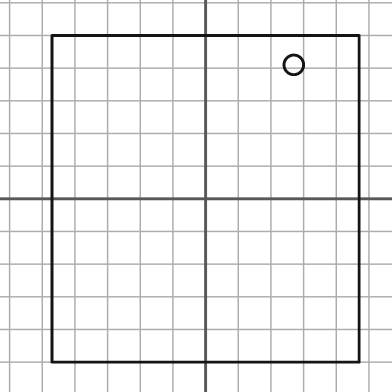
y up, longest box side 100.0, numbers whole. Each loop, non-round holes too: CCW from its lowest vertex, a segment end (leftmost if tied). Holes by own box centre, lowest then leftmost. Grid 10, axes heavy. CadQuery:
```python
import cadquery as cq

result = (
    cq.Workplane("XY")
    .moveTo(-47.0, -50.0)
    .lineTo(47.0, -50.0)
    .lineTo(47.0, 50.0)
    .lineTo(-47.0, 50.0)
    .close()
    .moveTo(27.0, 41.0)
    .circle(3.0)
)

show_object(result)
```